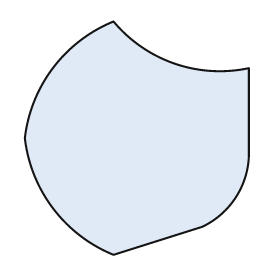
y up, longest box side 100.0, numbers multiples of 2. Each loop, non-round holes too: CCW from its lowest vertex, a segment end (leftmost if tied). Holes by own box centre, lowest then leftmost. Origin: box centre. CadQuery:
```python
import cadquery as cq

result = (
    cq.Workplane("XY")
    .moveTo(-10.0, -50.0)
    .lineTo(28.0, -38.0)
    .threePointArc((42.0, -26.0), (48.0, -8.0))
    .lineTo(48.0, 30.0)
    .threePointArc((16.0, 32.0), (-10.0, 50.0))
    .threePointArc((-36.0, 30.0), (-48.0, 0.0))
    .threePointArc((-36.0, -30.0), (-10.0, -50.0))
    .close()
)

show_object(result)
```